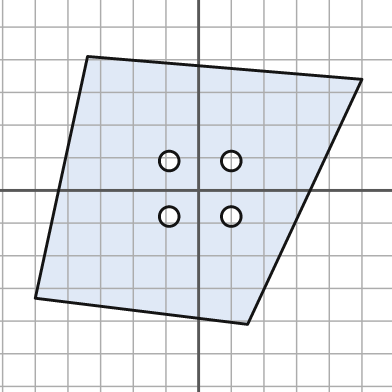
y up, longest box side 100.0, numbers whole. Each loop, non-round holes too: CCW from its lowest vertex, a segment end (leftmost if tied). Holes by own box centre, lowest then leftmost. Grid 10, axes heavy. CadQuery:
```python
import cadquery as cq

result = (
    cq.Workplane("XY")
    .moveTo(15.0, -41.0)
    .lineTo(50.0, 34.0)
    .lineTo(-34.0, 41.0)
    .lineTo(-50.0, -33.0)
    .close()
    .moveTo(-9.0, -8.0)
    .circle(3.0)
    .moveTo(10.0, -8.0)
    .circle(3.0)
    .moveTo(-9.0, 9.0)
    .circle(3.0)
    .moveTo(10.0, 9.0)
    .circle(3.0)
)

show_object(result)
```